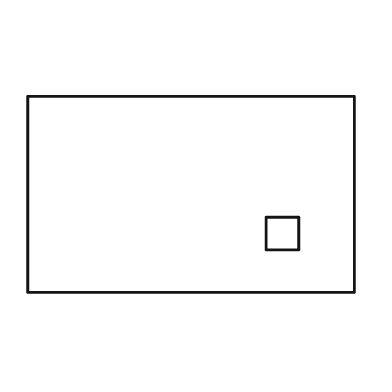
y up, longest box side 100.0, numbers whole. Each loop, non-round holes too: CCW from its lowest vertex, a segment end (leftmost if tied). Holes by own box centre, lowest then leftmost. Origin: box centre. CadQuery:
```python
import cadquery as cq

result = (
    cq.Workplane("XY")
    .moveTo(-50.0, -30.0)
    .lineTo(50.0, -30.0)
    .lineTo(50.0, 30.0)
    .lineTo(-50.0, 30.0)
    .close()
    .moveTo(23.0, -17.0)
    .lineTo(33.0, -17.0)
    .lineTo(33.0, -7.0)
    .lineTo(23.0, -7.0)
    .close()
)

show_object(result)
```